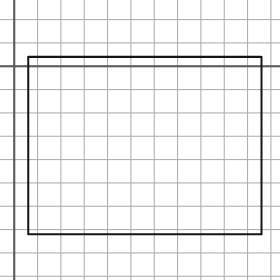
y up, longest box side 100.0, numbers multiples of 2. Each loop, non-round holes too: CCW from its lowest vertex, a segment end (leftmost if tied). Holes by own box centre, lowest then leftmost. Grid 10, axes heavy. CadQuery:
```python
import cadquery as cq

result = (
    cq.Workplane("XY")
    .moveTo(6.0, -72.0)
    .lineTo(106.0, -72.0)
    .lineTo(106.0, 4.0)
    .lineTo(6.0, 4.0)
    .close()
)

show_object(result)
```